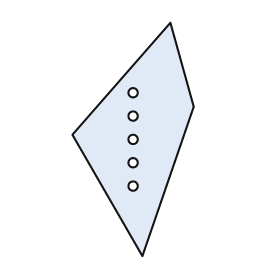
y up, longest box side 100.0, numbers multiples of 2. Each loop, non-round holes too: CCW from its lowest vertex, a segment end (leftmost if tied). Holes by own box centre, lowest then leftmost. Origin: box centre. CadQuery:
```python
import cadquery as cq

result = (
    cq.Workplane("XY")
    .moveTo(4.0, -50.0)
    .lineTo(26.0, 14.0)
    .lineTo(16.0, 50.0)
    .lineTo(-26.0, 2.0)
    .close()
    .moveTo(0.0, -20.0)
    .circle(2.0)
    .moveTo(0.0, -10.0)
    .circle(2.0)
    .moveTo(0.0, 0.0)
    .circle(2.0)
    .moveTo(0.0, 10.0)
    .circle(2.0)
    .moveTo(0.0, 20.0)
    .circle(2.0)
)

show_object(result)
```